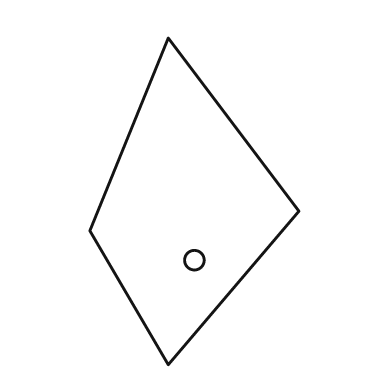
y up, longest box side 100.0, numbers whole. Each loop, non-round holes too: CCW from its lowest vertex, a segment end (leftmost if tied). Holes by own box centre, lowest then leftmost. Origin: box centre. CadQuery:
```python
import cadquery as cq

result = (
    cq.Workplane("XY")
    .moveTo(-8.0, -50.0)
    .lineTo(32.0, -3.0)
    .lineTo(-8.0, 50.0)
    .lineTo(-32.0, -9.0)
    .close()
    .moveTo(0.0, -18.0)
    .circle(3.0)
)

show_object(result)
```